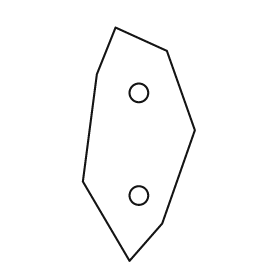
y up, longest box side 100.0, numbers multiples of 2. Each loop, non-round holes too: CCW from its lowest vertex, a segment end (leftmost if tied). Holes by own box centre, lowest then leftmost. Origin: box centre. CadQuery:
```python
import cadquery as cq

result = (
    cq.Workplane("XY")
    .moveTo(-4.0, -50.0)
    .lineTo(10.0, -34.0)
    .lineTo(24.0, 6.0)
    .lineTo(12.0, 40.0)
    .lineTo(-10.0, 50.0)
    .lineTo(-18.0, 30.0)
    .lineTo(-24.0, -16.0)
    .close()
    .moveTo(0.0, -22.0)
    .circle(4.0)
    .moveTo(0.0, 22.0)
    .circle(4.0)
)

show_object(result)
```